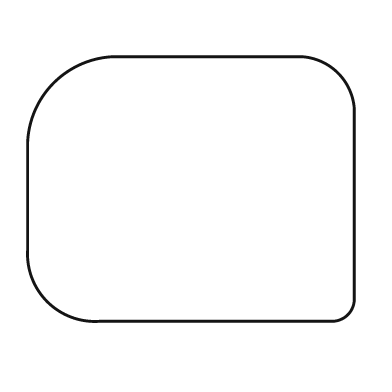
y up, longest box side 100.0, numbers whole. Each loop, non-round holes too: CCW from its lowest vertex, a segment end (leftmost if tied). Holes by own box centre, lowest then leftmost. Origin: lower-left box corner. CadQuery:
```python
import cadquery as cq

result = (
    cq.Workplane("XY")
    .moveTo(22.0, 0.0)
    .lineTo(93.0, 0.0)
    .threePointArc((98.0, 2.0), (100.0, 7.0))
    .lineTo(100.0, 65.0)
    .threePointArc((95.0, 76.0), (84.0, 81.0))
    .lineTo(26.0, 81.0)
    .threePointArc((8.0, 73.0), (0.0, 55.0))
    .lineTo(0.0, 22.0)
    .threePointArc((6.0, 6.0), (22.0, 0.0))
    .close()
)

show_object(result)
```